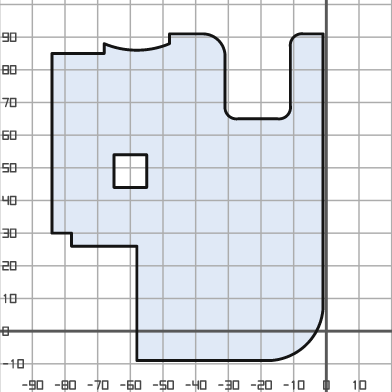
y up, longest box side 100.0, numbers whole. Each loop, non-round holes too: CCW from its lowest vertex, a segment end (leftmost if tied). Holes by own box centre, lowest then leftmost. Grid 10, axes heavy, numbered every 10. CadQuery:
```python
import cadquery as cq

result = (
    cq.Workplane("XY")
    .moveTo(-58.0, -9.0)
    .lineTo(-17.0, -9.0)
    .threePointArc((-6.0, -4.0), (-1.0, 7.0))
    .lineTo(-1.0, 91.0)
    .lineTo(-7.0, 91.0)
    .threePointArc((-10.0, 90.0), (-11.0, 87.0))
    .lineTo(-11.0, 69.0)
    .threePointArc((-12.0, 66.0), (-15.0, 65.0))
    .lineTo(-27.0, 65.0)
    .threePointArc((-30.0, 66.0), (-31.0, 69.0))
    .lineTo(-31.0, 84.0)
    .threePointArc((-33.0, 89.0), (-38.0, 91.0))
    .lineTo(-48.0, 91.0)
    .lineTo(-48.0, 88.0)
    .threePointArc((-58.0, 86.0), (-68.0, 88.0))
    .lineTo(-68.0, 85.0)
    .lineTo(-84.0, 85.0)
    .lineTo(-84.0, 30.0)
    .lineTo(-78.0, 30.0)
    .lineTo(-78.0, 26.0)
    .lineTo(-58.0, 26.0)
    .close()
    .moveTo(-65.0, 44.0)
    .lineTo(-55.0, 44.0)
    .lineTo(-55.0, 54.0)
    .lineTo(-65.0, 54.0)
    .close()
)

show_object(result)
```